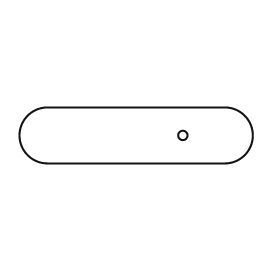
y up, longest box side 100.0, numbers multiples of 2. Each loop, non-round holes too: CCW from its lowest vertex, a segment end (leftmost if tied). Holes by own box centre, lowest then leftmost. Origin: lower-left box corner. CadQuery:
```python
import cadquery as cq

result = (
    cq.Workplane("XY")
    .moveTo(12.0, 0.0)
    .lineTo(88.0, 0.0)
    .threePointArc((100.0, 12.0), (88.0, 24.0))
    .lineTo(12.0, 24.0)
    .threePointArc((0.0, 12.0), (12.0, 0.0))
    .close()
    .moveTo(70.0, 12.0)
    .circle(2.0)
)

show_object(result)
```